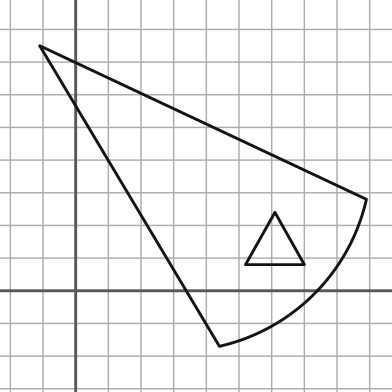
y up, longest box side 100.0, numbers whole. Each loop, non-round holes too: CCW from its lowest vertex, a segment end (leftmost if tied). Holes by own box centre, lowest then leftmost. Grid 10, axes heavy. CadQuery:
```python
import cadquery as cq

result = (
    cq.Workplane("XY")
    .moveTo(44.0, -17.0)
    .threePointArc((73.0, -1.0), (89.0, 28.0))
    .lineTo(-11.0, 75.0)
    .close()
    .moveTo(52.0, 8.0)
    .lineTo(70.0, 8.0)
    .lineTo(61.0, 24.0)
    .close()
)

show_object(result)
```